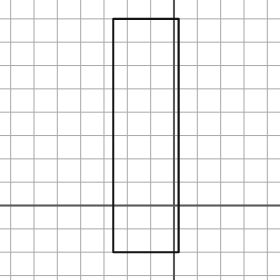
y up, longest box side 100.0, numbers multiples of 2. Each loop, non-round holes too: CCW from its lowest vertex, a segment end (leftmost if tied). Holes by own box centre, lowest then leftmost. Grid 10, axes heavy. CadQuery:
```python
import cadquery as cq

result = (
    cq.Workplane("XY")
    .moveTo(-26.0, -20.0)
    .lineTo(2.0, -20.0)
    .lineTo(2.0, 80.0)
    .lineTo(-26.0, 80.0)
    .close()
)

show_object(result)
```